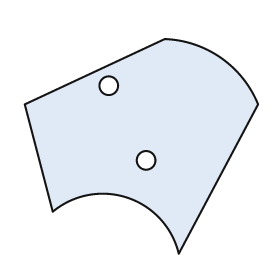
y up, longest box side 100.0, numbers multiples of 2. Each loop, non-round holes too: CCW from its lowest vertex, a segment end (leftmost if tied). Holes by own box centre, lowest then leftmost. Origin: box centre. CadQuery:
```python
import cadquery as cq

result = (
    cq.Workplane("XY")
    .moveTo(16.0, -46.0)
    .lineTo(50.0, 18.0)
    .threePointArc((34.0, 38.0), (10.0, 46.0))
    .lineTo(-50.0, 18.0)
    .lineTo(-38.0, -28.0)
    .threePointArc((-6.0, -22.0), (16.0, -46.0))
    .close()
    .moveTo(2.0, -6.0)
    .circle(4.0)
    .moveTo(-14.0, 26.0)
    .circle(4.0)
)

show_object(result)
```